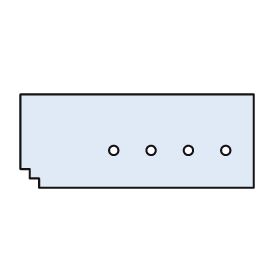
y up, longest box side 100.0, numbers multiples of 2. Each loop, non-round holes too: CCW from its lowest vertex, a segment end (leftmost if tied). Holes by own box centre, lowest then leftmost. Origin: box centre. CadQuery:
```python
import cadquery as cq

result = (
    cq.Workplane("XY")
    .moveTo(-42.0, -20.0)
    .lineTo(50.0, -20.0)
    .lineTo(50.0, 20.0)
    .lineTo(-50.0, 20.0)
    .lineTo(-50.0, -12.0)
    .lineTo(-46.0, -12.0)
    .lineTo(-46.0, -16.0)
    .lineTo(-42.0, -16.0)
    .close()
    .moveTo(-10.0, -4.0)
    .circle(2.0)
    .moveTo(6.0, -4.0)
    .circle(2.0)
    .moveTo(22.0, -4.0)
    .circle(2.0)
    .moveTo(38.0, -4.0)
    .circle(2.0)
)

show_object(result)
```